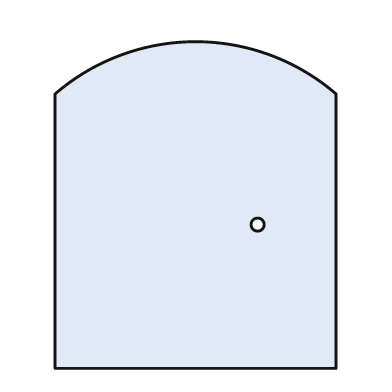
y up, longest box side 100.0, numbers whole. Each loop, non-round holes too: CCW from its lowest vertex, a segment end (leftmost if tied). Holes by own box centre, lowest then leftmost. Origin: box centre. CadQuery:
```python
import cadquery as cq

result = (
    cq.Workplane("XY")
    .moveTo(-43.0, -50.0)
    .lineTo(43.0, -50.0)
    .lineTo(43.0, 34.0)
    .threePointArc((0.0, 50.0), (-43.0, 34.0))
    .close()
    .moveTo(19.0, -6.0)
    .circle(2.0)
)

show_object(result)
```